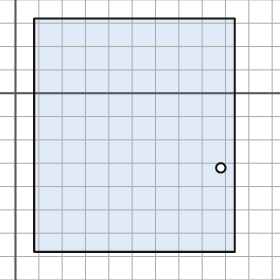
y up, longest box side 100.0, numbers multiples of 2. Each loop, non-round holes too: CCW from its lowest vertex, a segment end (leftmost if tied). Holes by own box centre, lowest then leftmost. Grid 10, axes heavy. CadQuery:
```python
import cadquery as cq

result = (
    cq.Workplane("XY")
    .moveTo(8.0, -68.0)
    .lineTo(94.0, -68.0)
    .lineTo(94.0, 32.0)
    .lineTo(8.0, 32.0)
    .close()
    .moveTo(88.0, -32.0)
    .circle(2.0)
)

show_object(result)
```